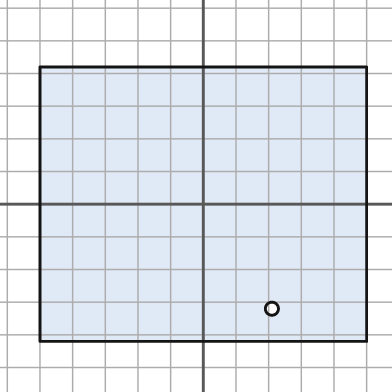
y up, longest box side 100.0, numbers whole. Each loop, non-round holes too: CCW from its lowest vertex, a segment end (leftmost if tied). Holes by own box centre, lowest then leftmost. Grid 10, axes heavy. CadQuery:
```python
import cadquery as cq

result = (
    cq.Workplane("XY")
    .moveTo(-50.0, -42.0)
    .lineTo(50.0, -42.0)
    .lineTo(50.0, 42.0)
    .lineTo(-50.0, 42.0)
    .close()
    .moveTo(21.0, -32.0)
    .circle(2.0)
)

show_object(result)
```